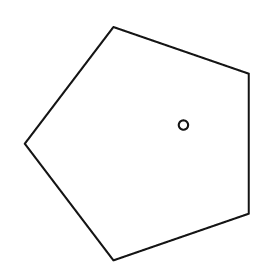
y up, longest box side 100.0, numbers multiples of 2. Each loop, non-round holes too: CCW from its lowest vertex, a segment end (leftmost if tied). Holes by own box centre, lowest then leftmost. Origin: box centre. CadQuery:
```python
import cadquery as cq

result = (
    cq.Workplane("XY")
    .moveTo(-10.0, -50.0)
    .lineTo(48.0, -30.0)
    .lineTo(48.0, 30.0)
    .lineTo(-10.0, 50.0)
    .lineTo(-48.0, 0.0)
    .close()
    .moveTo(20.0, 8.0)
    .circle(2.0)
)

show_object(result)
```